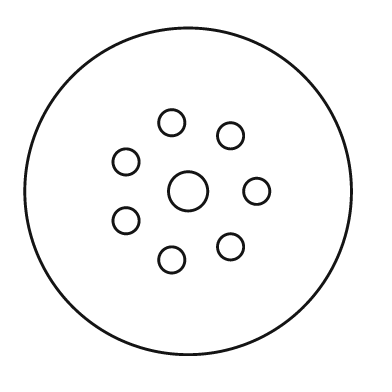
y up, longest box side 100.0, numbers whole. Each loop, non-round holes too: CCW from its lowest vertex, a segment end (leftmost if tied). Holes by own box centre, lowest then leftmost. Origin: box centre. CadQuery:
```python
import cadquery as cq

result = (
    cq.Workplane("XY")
    .moveTo(0.0, 0.0)
    .circle(50.0)
    .moveTo(-5.0, -21.0)
    .circle(4.0)
    .moveTo(13.0, -17.0)
    .circle(4.0)
    .moveTo(-19.0, -9.0)
    .circle(4.0)
    .moveTo(0.0, 0.0)
    .circle(6.0)
    .moveTo(21.0, 0.0)
    .circle(4.0)
    .moveTo(-19.0, 9.0)
    .circle(4.0)
    .moveTo(13.0, 17.0)
    .circle(4.0)
    .moveTo(-5.0, 21.0)
    .circle(4.0)
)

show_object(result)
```